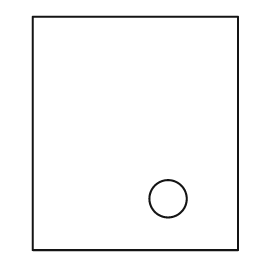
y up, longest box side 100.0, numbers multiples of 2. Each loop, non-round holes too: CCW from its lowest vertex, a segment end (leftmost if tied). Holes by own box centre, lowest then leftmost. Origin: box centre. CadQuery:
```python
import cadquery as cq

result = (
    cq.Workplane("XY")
    .moveTo(-44.0, -50.0)
    .lineTo(44.0, -50.0)
    .lineTo(44.0, 50.0)
    .lineTo(-44.0, 50.0)
    .close()
    .moveTo(14.0, -28.0)
    .circle(8.0)
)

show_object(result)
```